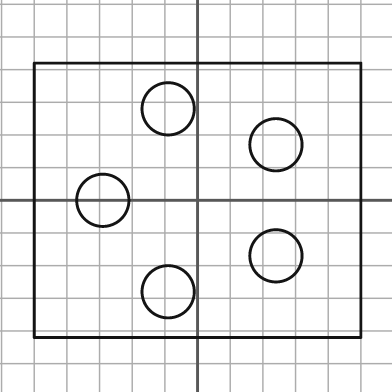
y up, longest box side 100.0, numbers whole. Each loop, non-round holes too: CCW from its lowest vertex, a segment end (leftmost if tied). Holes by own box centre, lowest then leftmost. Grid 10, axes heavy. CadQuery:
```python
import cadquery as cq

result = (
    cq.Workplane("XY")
    .moveTo(-50.0, -42.0)
    .lineTo(50.0, -42.0)
    .lineTo(50.0, 42.0)
    .lineTo(-50.0, 42.0)
    .close()
    .moveTo(-9.0, -28.0)
    .circle(8.0)
    .moveTo(24.0, -17.0)
    .circle(8.0)
    .moveTo(-29.0, 0.0)
    .circle(8.0)
    .moveTo(24.0, 17.0)
    .circle(8.0)
    .moveTo(-9.0, 28.0)
    .circle(8.0)
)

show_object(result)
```